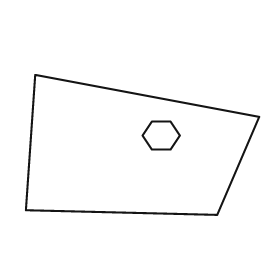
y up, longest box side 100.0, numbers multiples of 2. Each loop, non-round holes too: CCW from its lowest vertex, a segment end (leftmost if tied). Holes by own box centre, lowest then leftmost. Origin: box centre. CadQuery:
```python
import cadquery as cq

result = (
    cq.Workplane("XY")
    .moveTo(32.0, -30.0)
    .lineTo(50.0, 12.0)
    .lineTo(-46.0, 30.0)
    .lineTo(-50.0, -28.0)
    .close()
    .moveTo(4.0, -2.0)
    .lineTo(12.0, -2.0)
    .lineTo(16.0, 4.0)
    .lineTo(12.0, 10.0)
    .lineTo(4.0, 10.0)
    .lineTo(0.0, 4.0)
    .close()
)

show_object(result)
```